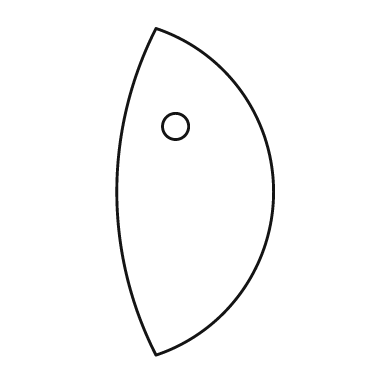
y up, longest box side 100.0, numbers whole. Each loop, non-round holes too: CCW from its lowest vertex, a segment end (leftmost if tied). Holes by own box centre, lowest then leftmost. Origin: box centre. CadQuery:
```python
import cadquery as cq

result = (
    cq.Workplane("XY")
    .moveTo(-12.0, -50.0)
    .threePointArc((24.0, 0.0), (-12.0, 50.0))
    .threePointArc((-24.0, 0.0), (-12.0, -50.0))
    .close()
    .moveTo(-6.0, 20.0)
    .circle(4.0)
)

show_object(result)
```